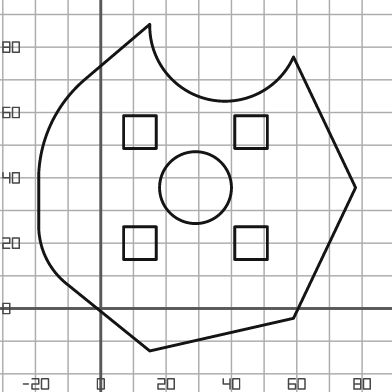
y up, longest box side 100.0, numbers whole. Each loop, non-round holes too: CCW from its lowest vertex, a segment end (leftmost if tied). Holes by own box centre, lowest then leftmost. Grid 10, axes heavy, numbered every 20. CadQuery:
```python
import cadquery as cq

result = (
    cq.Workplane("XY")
    .moveTo(15.0, -13.0)
    .lineTo(59.0, -3.0)
    .lineTo(78.0, 37.0)
    .lineTo(59.0, 77.0)
    .threePointArc((33.0, 64.0), (15.0, 87.0))
    .lineTo(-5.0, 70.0)
    .threePointArc((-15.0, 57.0), (-19.0, 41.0))
    .lineTo(-19.0, 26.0)
    .threePointArc((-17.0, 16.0), (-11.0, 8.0))
    .close()
    .moveTo(7.0, 15.0)
    .lineTo(17.0, 15.0)
    .lineTo(17.0, 25.0)
    .lineTo(7.0, 25.0)
    .close()
    .moveTo(41.0, 15.0)
    .lineTo(51.0, 15.0)
    .lineTo(51.0, 25.0)
    .lineTo(41.0, 25.0)
    .close()
    .moveTo(29.0, 37.0)
    .circle(11.0)
    .moveTo(7.0, 49.0)
    .lineTo(17.0, 49.0)
    .lineTo(17.0, 59.0)
    .lineTo(7.0, 59.0)
    .close()
    .moveTo(41.0, 49.0)
    .lineTo(51.0, 49.0)
    .lineTo(51.0, 59.0)
    .lineTo(41.0, 59.0)
    .close()
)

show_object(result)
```